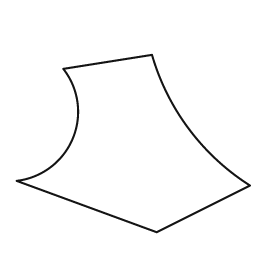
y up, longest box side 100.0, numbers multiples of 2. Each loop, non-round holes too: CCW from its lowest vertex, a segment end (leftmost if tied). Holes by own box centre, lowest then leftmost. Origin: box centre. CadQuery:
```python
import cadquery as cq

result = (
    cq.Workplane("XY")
    .moveTo(10.0, -38.0)
    .lineTo(50.0, -18.0)
    .threePointArc((24.0, 6.0), (8.0, 38.0))
    .lineTo(-30.0, 32.0)
    .threePointArc((-26.0, 2.0), (-50.0, -16.0))
    .close()
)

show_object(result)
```